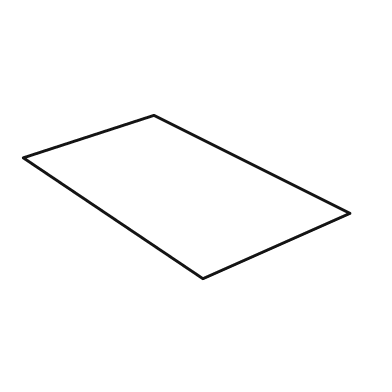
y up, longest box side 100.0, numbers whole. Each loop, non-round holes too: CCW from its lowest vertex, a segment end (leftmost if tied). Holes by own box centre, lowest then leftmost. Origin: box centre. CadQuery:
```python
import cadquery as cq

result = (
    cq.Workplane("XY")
    .moveTo(5.0, -25.0)
    .lineTo(50.0, -5.0)
    .lineTo(-10.0, 25.0)
    .lineTo(-50.0, 12.0)
    .close()
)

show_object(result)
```